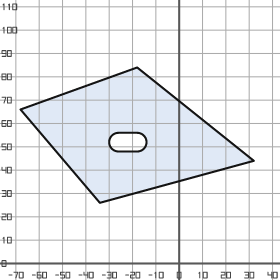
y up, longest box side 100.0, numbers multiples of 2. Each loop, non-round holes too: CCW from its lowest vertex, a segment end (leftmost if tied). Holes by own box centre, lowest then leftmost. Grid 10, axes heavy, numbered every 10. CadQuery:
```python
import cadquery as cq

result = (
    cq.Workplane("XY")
    .moveTo(-34.0, 26.0)
    .lineTo(32.0, 44.0)
    .lineTo(-18.0, 84.0)
    .lineTo(-68.0, 66.0)
    .close()
    .moveTo(-26.0, 48.0)
    .lineTo(-18.0, 48.0)
    .threePointArc((-14.0, 52.0), (-18.0, 56.0))
    .lineTo(-26.0, 56.0)
    .threePointArc((-30.0, 52.0), (-26.0, 48.0))
    .close()
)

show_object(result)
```